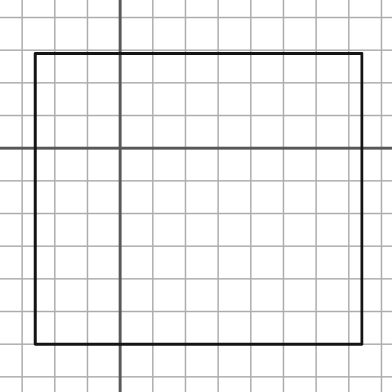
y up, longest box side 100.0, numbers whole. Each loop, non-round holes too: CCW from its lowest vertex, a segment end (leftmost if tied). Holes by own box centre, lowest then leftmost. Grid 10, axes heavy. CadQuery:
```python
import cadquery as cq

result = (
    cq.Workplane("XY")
    .moveTo(-26.0, -60.0)
    .lineTo(74.0, -60.0)
    .lineTo(74.0, 29.0)
    .lineTo(-26.0, 29.0)
    .close()
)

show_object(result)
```